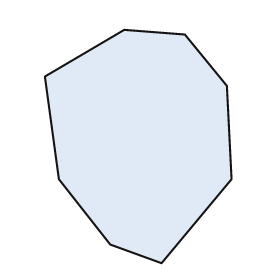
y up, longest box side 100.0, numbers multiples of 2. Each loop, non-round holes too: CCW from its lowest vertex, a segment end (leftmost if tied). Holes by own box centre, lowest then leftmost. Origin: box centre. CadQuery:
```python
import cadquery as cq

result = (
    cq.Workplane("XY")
    .moveTo(10.0, -50.0)
    .lineTo(40.0, -14.0)
    .lineTo(38.0, 26.0)
    .lineTo(20.0, 48.0)
    .lineTo(-6.0, 50.0)
    .lineTo(-40.0, 30.0)
    .lineTo(-34.0, -14.0)
    .lineTo(-12.0, -42.0)
    .close()
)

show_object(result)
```